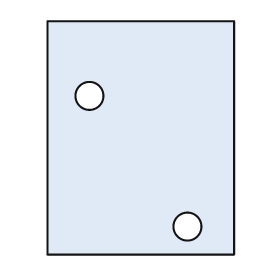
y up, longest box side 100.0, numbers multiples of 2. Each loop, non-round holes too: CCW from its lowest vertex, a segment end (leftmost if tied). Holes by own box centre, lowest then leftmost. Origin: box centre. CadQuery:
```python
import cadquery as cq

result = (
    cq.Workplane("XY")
    .moveTo(-40.0, -50.0)
    .lineTo(40.0, -50.0)
    .lineTo(40.0, 50.0)
    .lineTo(-40.0, 50.0)
    .close()
    .moveTo(20.0, -38.0)
    .circle(6.0)
    .moveTo(-22.0, 18.0)
    .circle(6.0)
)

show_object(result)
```